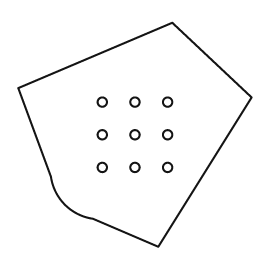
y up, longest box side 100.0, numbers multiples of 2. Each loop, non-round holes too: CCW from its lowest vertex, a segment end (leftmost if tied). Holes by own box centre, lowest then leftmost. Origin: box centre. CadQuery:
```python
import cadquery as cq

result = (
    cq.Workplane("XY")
    .moveTo(10.0, -48.0)
    .lineTo(50.0, 16.0)
    .lineTo(16.0, 48.0)
    .lineTo(-50.0, 20.0)
    .lineTo(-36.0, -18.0)
    .threePointArc((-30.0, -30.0), (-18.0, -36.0))
    .close()
    .moveTo(-14.0, -14.0)
    .circle(2.0)
    .moveTo(0.0, -14.0)
    .circle(2.0)
    .moveTo(14.0, -14.0)
    .circle(2.0)
    .moveTo(-14.0, 0.0)
    .circle(2.0)
    .moveTo(0.0, 0.0)
    .circle(2.0)
    .moveTo(14.0, 0.0)
    .circle(2.0)
    .moveTo(-14.0, 14.0)
    .circle(2.0)
    .moveTo(0.0, 14.0)
    .circle(2.0)
    .moveTo(14.0, 14.0)
    .circle(2.0)
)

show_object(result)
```